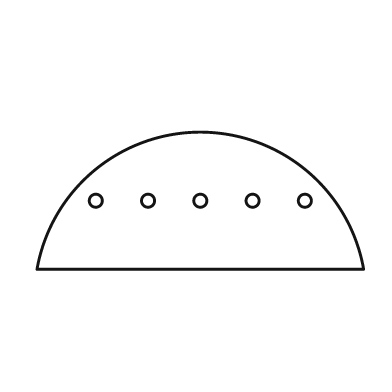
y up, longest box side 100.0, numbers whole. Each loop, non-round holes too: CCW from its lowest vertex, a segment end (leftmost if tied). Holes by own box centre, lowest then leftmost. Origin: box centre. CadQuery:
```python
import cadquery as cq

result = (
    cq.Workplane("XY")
    .moveTo(-50.0, -21.0)
    .lineTo(50.0, -21.0)
    .threePointArc((0.0, 21.0), (-50.0, -21.0))
    .close()
    .moveTo(-32.0, 0.0)
    .circle(2.0)
    .moveTo(-16.0, 0.0)
    .circle(2.0)
    .moveTo(0.0, 0.0)
    .circle(2.0)
    .moveTo(16.0, 0.0)
    .circle(2.0)
    .moveTo(32.0, 0.0)
    .circle(2.0)
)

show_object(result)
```